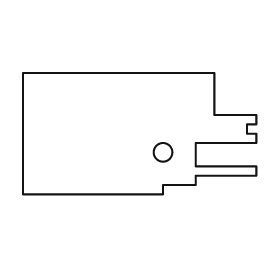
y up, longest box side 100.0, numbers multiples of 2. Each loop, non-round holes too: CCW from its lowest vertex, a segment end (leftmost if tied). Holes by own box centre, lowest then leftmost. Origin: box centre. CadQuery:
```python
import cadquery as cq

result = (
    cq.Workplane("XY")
    .moveTo(-50.0, -26.0)
    .lineTo(10.0, -26.0)
    .lineTo(10.0, -22.0)
    .lineTo(24.0, -22.0)
    .lineTo(24.0, -18.0)
    .lineTo(50.0, -18.0)
    .lineTo(50.0, -14.0)
    .lineTo(24.0, -14.0)
    .lineTo(24.0, -4.0)
    .lineTo(50.0, -4.0)
    .lineTo(50.0, 0.0)
    .lineTo(46.0, 0.0)
    .lineTo(46.0, 4.0)
    .lineTo(50.0, 4.0)
    .lineTo(50.0, 8.0)
    .lineTo(32.0, 8.0)
    .lineTo(32.0, 26.0)
    .lineTo(-50.0, 26.0)
    .close()
    .moveTo(10.0, -8.0)
    .circle(4.0)
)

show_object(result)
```